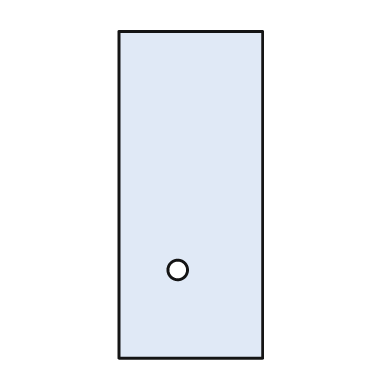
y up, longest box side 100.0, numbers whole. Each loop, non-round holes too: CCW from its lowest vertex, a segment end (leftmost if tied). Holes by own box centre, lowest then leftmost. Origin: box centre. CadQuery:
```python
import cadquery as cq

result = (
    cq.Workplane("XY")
    .moveTo(-22.0, -50.0)
    .lineTo(22.0, -50.0)
    .lineTo(22.0, 50.0)
    .lineTo(-22.0, 50.0)
    .close()
    .moveTo(-4.0, -23.0)
    .circle(3.0)
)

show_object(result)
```